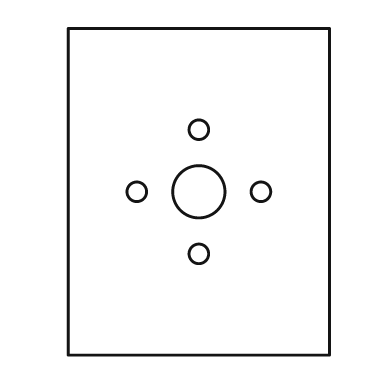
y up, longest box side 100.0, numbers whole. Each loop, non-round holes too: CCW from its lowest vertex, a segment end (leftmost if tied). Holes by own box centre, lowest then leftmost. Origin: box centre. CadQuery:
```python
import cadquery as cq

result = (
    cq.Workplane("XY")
    .moveTo(-40.0, -50.0)
    .lineTo(40.0, -50.0)
    .lineTo(40.0, 50.0)
    .lineTo(-40.0, 50.0)
    .close()
    .moveTo(0.0, -19.0)
    .circle(3.0)
    .moveTo(-19.0, 0.0)
    .circle(3.0)
    .moveTo(0.0, 0.0)
    .circle(8.0)
    .moveTo(19.0, 0.0)
    .circle(3.0)
    .moveTo(0.0, 19.0)
    .circle(3.0)
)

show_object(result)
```